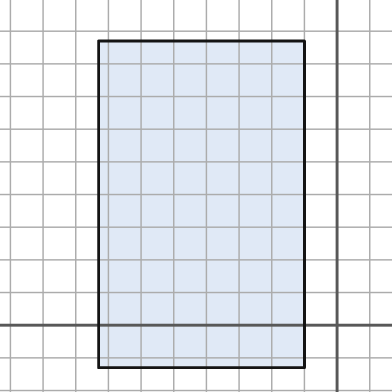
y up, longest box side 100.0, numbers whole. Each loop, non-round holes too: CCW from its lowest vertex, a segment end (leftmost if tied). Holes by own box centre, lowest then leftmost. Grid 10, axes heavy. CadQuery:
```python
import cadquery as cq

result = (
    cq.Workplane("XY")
    .moveTo(-73.0, -13.0)
    .lineTo(-10.0, -13.0)
    .lineTo(-10.0, 87.0)
    .lineTo(-73.0, 87.0)
    .close()
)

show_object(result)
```